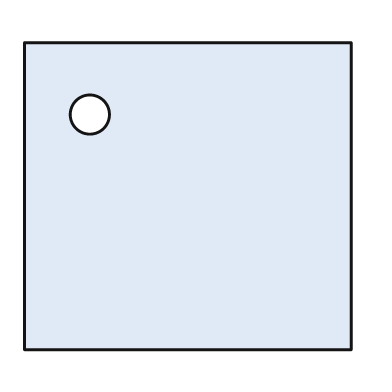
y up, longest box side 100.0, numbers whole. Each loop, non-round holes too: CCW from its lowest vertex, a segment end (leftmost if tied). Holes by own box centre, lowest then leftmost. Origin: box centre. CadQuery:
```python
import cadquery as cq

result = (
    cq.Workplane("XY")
    .moveTo(-50.0, -47.0)
    .lineTo(50.0, -47.0)
    .lineTo(50.0, 47.0)
    .lineTo(-50.0, 47.0)
    .close()
    .moveTo(-30.0, 25.0)
    .circle(6.0)
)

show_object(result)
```